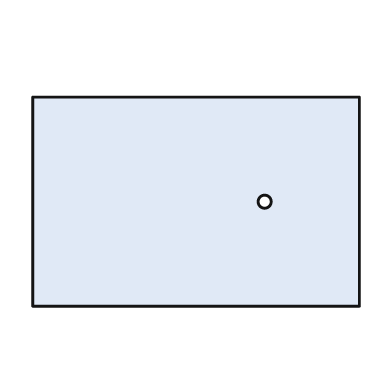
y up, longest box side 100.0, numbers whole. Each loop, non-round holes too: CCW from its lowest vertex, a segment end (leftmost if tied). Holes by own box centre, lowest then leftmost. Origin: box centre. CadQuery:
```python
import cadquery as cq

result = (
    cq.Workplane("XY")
    .moveTo(-50.0, -32.0)
    .lineTo(50.0, -32.0)
    .lineTo(50.0, 32.0)
    .lineTo(-50.0, 32.0)
    .close()
    .moveTo(21.0, 0.0)
    .circle(2.0)
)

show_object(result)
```